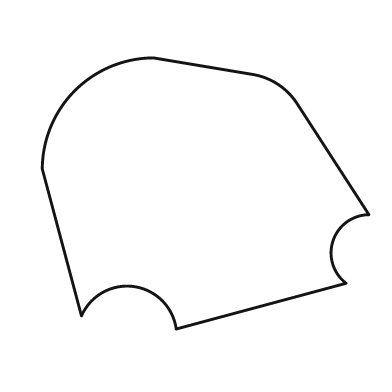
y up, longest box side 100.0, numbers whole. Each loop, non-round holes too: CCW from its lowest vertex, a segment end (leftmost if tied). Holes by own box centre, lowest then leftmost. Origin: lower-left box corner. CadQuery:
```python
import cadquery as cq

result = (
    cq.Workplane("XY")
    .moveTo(41.0, 0.0)
    .lineTo(93.0, 14.0)
    .threePointArc((89.0, 27.0), (100.0, 35.0))
    .lineTo(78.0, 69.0)
    .threePointArc((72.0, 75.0), (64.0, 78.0))
    .lineTo(34.0, 83.0)
    .threePointArc((10.0, 73.0), (0.0, 49.0))
    .lineTo(12.0, 4.0)
    .threePointArc((28.0, 13.0), (41.0, 0.0))
    .close()
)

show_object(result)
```